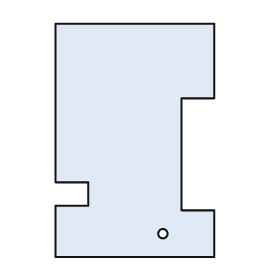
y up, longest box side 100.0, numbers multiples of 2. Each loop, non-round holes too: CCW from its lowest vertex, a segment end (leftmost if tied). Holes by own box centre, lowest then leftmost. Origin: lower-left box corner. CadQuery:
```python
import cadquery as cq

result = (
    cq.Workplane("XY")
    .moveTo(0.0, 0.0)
    .lineTo(68.0, 0.0)
    .lineTo(68.0, 20.0)
    .lineTo(54.0, 20.0)
    .lineTo(54.0, 68.0)
    .lineTo(68.0, 68.0)
    .lineTo(68.0, 100.0)
    .lineTo(0.0, 100.0)
    .lineTo(0.0, 32.0)
    .lineTo(14.0, 32.0)
    .lineTo(14.0, 22.0)
    .lineTo(0.0, 22.0)
    .close()
    .moveTo(46.0, 10.0)
    .circle(2.0)
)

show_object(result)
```